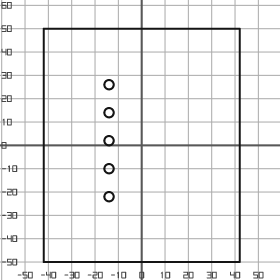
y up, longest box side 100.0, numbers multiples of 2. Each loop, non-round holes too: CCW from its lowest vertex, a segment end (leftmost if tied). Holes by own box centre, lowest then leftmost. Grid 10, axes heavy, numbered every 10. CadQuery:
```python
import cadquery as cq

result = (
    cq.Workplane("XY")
    .moveTo(-42.0, -50.0)
    .lineTo(42.0, -50.0)
    .lineTo(42.0, 50.0)
    .lineTo(-42.0, 50.0)
    .close()
    .moveTo(-14.0, -22.0)
    .circle(2.0)
    .moveTo(-14.0, -10.0)
    .circle(2.0)
    .moveTo(-14.0, 2.0)
    .circle(2.0)
    .moveTo(-14.0, 14.0)
    .circle(2.0)
    .moveTo(-14.0, 26.0)
    .circle(2.0)
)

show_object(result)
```